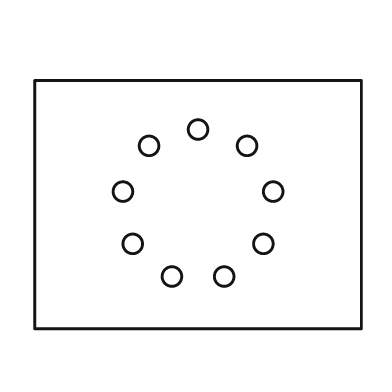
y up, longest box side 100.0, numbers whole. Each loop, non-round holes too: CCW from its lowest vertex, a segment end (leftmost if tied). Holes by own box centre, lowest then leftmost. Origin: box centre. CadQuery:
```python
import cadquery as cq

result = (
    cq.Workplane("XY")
    .moveTo(-50.0, -38.0)
    .lineTo(50.0, -38.0)
    .lineTo(50.0, 38.0)
    .lineTo(-50.0, 38.0)
    .close()
    .moveTo(-8.0, -22.0)
    .circle(3.0)
    .moveTo(8.0, -22.0)
    .circle(3.0)
    .moveTo(-20.0, -12.0)
    .circle(3.0)
    .moveTo(20.0, -12.0)
    .circle(3.0)
    .moveTo(-23.0, 4.0)
    .circle(3.0)
    .moveTo(23.0, 4.0)
    .circle(3.0)
    .moveTo(-15.0, 18.0)
    .circle(3.0)
    .moveTo(15.0, 18.0)
    .circle(3.0)
    .moveTo(0.0, 23.0)
    .circle(3.0)
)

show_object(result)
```